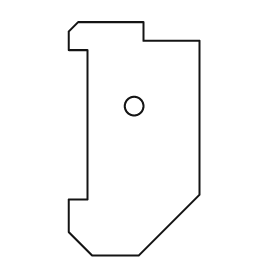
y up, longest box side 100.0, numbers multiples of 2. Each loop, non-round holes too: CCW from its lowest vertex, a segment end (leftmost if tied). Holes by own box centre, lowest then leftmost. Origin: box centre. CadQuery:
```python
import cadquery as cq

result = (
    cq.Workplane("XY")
    .moveTo(-18.0, -50.0)
    .lineTo(2.0, -50.0)
    .lineTo(28.0, -24.0)
    .lineTo(28.0, 42.0)
    .lineTo(4.0, 42.0)
    .lineTo(4.0, 50.0)
    .lineTo(-24.0, 50.0)
    .lineTo(-28.0, 46.0)
    .lineTo(-28.0, 38.0)
    .lineTo(-20.0, 38.0)
    .lineTo(-20.0, -26.0)
    .lineTo(-28.0, -26.0)
    .lineTo(-28.0, -40.0)
    .close()
    .moveTo(0.0, 14.0)
    .circle(4.0)
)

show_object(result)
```